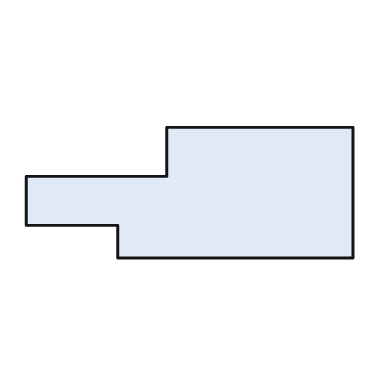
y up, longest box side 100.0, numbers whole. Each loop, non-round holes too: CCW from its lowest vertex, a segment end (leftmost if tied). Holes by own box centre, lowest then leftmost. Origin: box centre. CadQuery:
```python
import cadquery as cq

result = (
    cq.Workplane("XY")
    .moveTo(-22.0, -20.0)
    .lineTo(50.0, -20.0)
    .lineTo(50.0, 20.0)
    .lineTo(-7.0, 20.0)
    .lineTo(-7.0, 5.0)
    .lineTo(-50.0, 5.0)
    .lineTo(-50.0, -10.0)
    .lineTo(-22.0, -10.0)
    .close()
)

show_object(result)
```